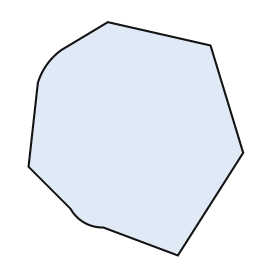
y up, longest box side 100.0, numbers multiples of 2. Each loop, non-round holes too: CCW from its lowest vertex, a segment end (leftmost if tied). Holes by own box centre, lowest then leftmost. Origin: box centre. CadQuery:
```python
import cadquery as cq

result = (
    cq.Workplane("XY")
    .moveTo(18.0, -50.0)
    .lineTo(46.0, -6.0)
    .lineTo(32.0, 40.0)
    .lineTo(-12.0, 50.0)
    .lineTo(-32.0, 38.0)
    .threePointArc((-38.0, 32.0), (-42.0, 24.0))
    .lineTo(-46.0, -12.0)
    .lineTo(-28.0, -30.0)
    .threePointArc((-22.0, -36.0), (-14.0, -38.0))
    .close()
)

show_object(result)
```